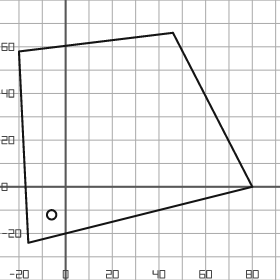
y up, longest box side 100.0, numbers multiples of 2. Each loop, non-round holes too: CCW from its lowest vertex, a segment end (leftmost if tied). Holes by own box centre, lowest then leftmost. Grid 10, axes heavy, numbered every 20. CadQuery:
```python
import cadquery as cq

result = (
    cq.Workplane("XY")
    .moveTo(-16.0, -24.0)
    .lineTo(80.0, 0.0)
    .lineTo(46.0, 66.0)
    .lineTo(-20.0, 58.0)
    .close()
    .moveTo(-6.0, -12.0)
    .circle(2.0)
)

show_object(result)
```